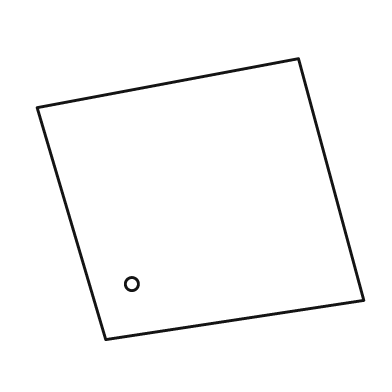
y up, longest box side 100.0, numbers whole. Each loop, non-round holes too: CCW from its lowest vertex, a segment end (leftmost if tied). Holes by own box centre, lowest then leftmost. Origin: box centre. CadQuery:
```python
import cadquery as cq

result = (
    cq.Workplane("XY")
    .moveTo(-29.0, -43.0)
    .lineTo(50.0, -31.0)
    .lineTo(30.0, 43.0)
    .lineTo(-50.0, 28.0)
    .close()
    .moveTo(-21.0, -26.0)
    .circle(2.0)
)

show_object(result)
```